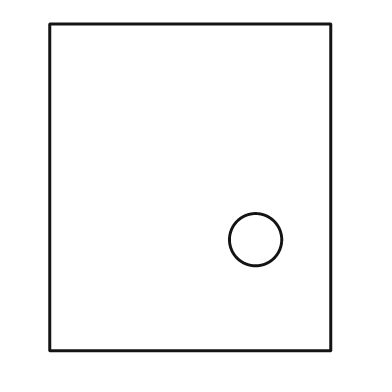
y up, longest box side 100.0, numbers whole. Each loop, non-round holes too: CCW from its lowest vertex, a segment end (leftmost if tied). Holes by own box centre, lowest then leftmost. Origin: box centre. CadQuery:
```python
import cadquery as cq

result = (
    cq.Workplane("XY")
    .moveTo(-43.0, -50.0)
    .lineTo(43.0, -50.0)
    .lineTo(43.0, 50.0)
    .lineTo(-43.0, 50.0)
    .close()
    .moveTo(20.0, -16.0)
    .circle(8.0)
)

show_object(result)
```